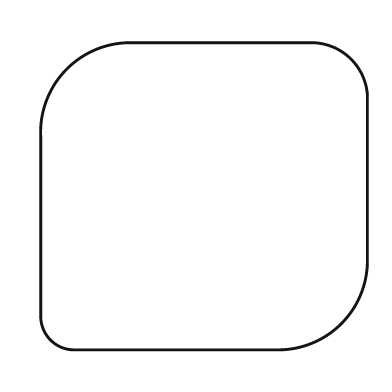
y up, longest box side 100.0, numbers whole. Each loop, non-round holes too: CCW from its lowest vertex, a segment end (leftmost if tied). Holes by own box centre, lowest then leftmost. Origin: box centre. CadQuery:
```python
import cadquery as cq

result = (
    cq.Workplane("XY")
    .moveTo(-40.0, -47.0)
    .lineTo(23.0, -47.0)
    .threePointArc((42.0, -39.0), (50.0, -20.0))
    .lineTo(50.0, 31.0)
    .threePointArc((45.0, 42.0), (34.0, 47.0))
    .lineTo(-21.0, 47.0)
    .threePointArc((-42.0, 39.0), (-50.0, 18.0))
    .lineTo(-50.0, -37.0)
    .threePointArc((-47.0, -44.0), (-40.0, -47.0))
    .close()
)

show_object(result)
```